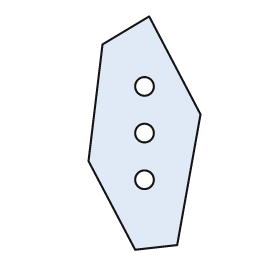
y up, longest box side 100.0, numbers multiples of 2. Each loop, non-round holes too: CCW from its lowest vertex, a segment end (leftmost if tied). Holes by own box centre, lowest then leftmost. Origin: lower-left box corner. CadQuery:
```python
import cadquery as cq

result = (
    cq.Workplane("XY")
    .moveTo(20.0, 0.0)
    .lineTo(38.0, 2.0)
    .lineTo(48.0, 58.0)
    .lineTo(26.0, 100.0)
    .lineTo(6.0, 88.0)
    .lineTo(0.0, 38.0)
    .close()
    .moveTo(24.0, 30.0)
    .circle(4.0)
    .moveTo(24.0, 50.0)
    .circle(4.0)
    .moveTo(24.0, 70.0)
    .circle(4.0)
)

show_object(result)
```